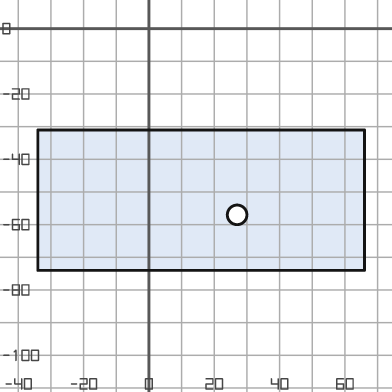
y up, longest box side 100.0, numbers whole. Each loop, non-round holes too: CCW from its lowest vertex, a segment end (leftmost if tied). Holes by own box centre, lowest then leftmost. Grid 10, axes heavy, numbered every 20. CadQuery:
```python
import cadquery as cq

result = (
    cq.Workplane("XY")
    .moveTo(-34.0, -74.0)
    .lineTo(66.0, -74.0)
    .lineTo(66.0, -31.0)
    .lineTo(-34.0, -31.0)
    .close()
    .moveTo(27.0, -57.0)
    .circle(3.0)
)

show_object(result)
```